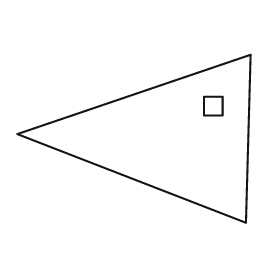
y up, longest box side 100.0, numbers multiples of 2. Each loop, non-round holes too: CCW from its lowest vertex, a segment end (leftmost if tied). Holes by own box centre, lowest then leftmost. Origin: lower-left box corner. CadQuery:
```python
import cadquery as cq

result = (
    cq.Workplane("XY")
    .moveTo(98.0, 0.0)
    .lineTo(100.0, 72.0)
    .lineTo(0.0, 38.0)
    .close()
    .moveTo(80.0, 46.0)
    .lineTo(88.0, 46.0)
    .lineTo(88.0, 54.0)
    .lineTo(80.0, 54.0)
    .close()
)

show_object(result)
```